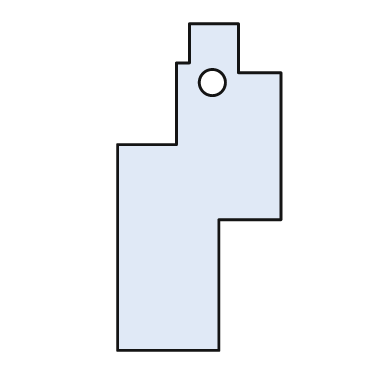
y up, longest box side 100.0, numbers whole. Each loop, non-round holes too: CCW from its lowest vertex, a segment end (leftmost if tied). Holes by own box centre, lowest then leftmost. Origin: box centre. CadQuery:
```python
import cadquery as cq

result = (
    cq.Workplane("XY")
    .moveTo(-25.0, -50.0)
    .lineTo(6.0, -50.0)
    .lineTo(6.0, -10.0)
    .lineTo(25.0, -10.0)
    .lineTo(25.0, 35.0)
    .lineTo(12.0, 35.0)
    .lineTo(12.0, 50.0)
    .lineTo(-3.0, 50.0)
    .lineTo(-3.0, 38.0)
    .lineTo(-7.0, 38.0)
    .lineTo(-7.0, 13.0)
    .lineTo(-25.0, 13.0)
    .close()
    .moveTo(4.0, 32.0)
    .circle(4.0)
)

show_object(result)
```